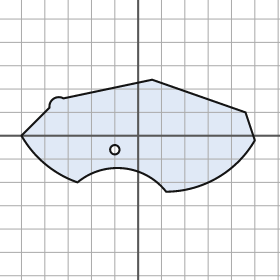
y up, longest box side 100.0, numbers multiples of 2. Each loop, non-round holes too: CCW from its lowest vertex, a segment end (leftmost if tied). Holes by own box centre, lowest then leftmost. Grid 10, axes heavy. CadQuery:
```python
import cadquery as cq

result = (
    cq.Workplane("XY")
    .moveTo(12.0, -24.0)
    .threePointArc((34.0, -18.0), (50.0, -2.0))
    .lineTo(46.0, 10.0)
    .lineTo(6.0, 24.0)
    .lineTo(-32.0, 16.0)
    .threePointArc((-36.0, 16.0), (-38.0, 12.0))
    .lineTo(-50.0, 0.0)
    .threePointArc((-40.0, -12.0), (-26.0, -20.0))
    .threePointArc((-6.0, -14.0), (12.0, -24.0))
    .close()
    .moveTo(-10.0, -6.0)
    .circle(2.0)
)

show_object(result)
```